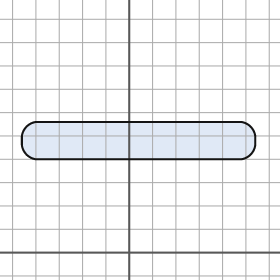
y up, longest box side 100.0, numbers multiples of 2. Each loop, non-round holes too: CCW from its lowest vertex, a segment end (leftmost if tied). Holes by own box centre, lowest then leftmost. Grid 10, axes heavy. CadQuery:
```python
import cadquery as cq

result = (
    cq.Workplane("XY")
    .moveTo(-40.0, 40.0)
    .lineTo(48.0, 40.0)
    .threePointArc((52.0, 42.0), (54.0, 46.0))
    .lineTo(54.0, 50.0)
    .threePointArc((52.0, 54.0), (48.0, 56.0))
    .lineTo(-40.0, 56.0)
    .threePointArc((-44.0, 54.0), (-46.0, 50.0))
    .lineTo(-46.0, 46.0)
    .threePointArc((-44.0, 42.0), (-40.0, 40.0))
    .close()
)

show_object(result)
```